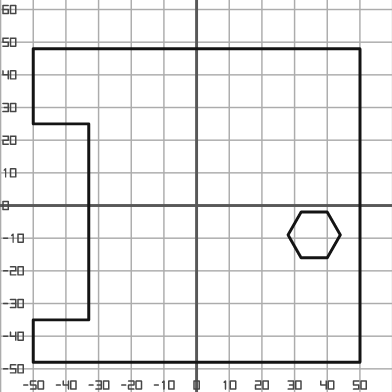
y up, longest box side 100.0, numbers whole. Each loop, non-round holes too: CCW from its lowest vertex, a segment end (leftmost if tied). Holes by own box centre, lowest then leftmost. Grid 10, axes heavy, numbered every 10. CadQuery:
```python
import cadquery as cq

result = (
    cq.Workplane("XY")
    .moveTo(-50.0, -48.0)
    .lineTo(50.0, -48.0)
    .lineTo(50.0, 48.0)
    .lineTo(-50.0, 48.0)
    .lineTo(-50.0, 25.0)
    .lineTo(-33.0, 25.0)
    .lineTo(-33.0, -35.0)
    .lineTo(-50.0, -35.0)
    .close()
    .moveTo(32.0, -16.0)
    .lineTo(40.0, -16.0)
    .lineTo(44.0, -9.0)
    .lineTo(40.0, -2.0)
    .lineTo(32.0, -2.0)
    .lineTo(28.0, -9.0)
    .close()
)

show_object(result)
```